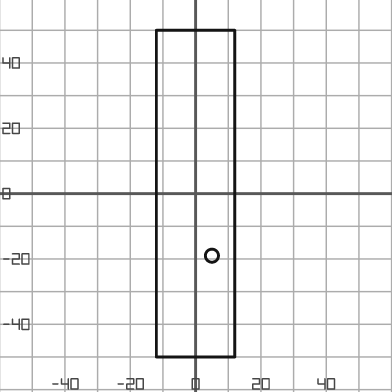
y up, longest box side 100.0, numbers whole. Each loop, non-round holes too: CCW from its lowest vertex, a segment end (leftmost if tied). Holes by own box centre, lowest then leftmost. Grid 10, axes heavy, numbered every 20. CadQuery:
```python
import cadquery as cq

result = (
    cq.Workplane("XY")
    .moveTo(-12.0, -50.0)
    .lineTo(12.0, -50.0)
    .lineTo(12.0, 50.0)
    .lineTo(-12.0, 50.0)
    .close()
    .moveTo(5.0, -19.0)
    .circle(2.0)
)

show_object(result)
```